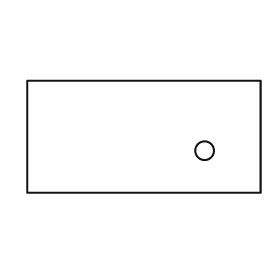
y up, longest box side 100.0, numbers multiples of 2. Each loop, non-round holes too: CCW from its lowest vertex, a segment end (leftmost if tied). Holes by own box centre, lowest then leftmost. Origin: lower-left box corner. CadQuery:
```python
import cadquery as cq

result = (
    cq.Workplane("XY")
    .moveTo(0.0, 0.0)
    .lineTo(100.0, 0.0)
    .lineTo(100.0, 48.0)
    .lineTo(0.0, 48.0)
    .close()
    .moveTo(76.0, 18.0)
    .circle(4.0)
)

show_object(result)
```